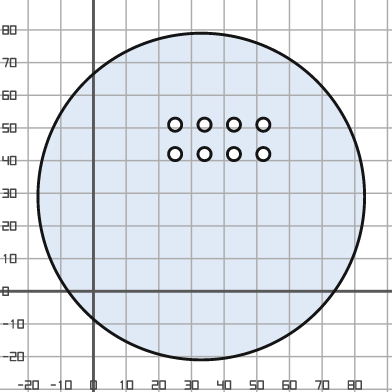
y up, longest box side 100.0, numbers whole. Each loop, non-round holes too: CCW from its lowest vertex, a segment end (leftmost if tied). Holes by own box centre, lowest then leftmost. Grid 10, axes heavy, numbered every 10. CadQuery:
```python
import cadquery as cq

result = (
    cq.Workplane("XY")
    .moveTo(33.0, 29.0)
    .circle(50.0)
    .moveTo(25.0, 42.0)
    .circle(2.0)
    .moveTo(34.0, 42.0)
    .circle(2.0)
    .moveTo(43.0, 42.0)
    .circle(2.0)
    .moveTo(52.0, 42.0)
    .circle(2.0)
    .moveTo(25.0, 51.0)
    .circle(2.0)
    .moveTo(34.0, 51.0)
    .circle(2.0)
    .moveTo(43.0, 51.0)
    .circle(2.0)
    .moveTo(52.0, 51.0)
    .circle(2.0)
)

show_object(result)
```